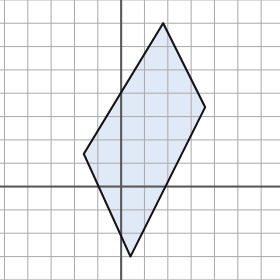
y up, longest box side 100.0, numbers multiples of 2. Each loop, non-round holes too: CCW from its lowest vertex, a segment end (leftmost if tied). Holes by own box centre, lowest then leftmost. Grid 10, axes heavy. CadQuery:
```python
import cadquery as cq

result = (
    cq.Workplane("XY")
    .moveTo(4.0, -30.0)
    .lineTo(36.0, 34.0)
    .lineTo(18.0, 70.0)
    .lineTo(-16.0, 14.0)
    .close()
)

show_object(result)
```